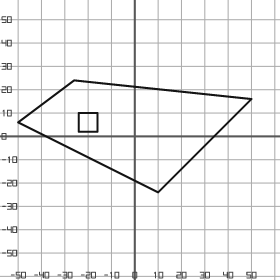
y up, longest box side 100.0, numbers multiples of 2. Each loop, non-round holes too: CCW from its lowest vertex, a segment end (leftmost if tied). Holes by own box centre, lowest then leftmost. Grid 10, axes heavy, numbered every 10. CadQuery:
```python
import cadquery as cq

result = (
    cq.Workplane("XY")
    .moveTo(10.0, -24.0)
    .lineTo(50.0, 16.0)
    .lineTo(-26.0, 24.0)
    .lineTo(-50.0, 6.0)
    .close()
    .moveTo(-24.0, 2.0)
    .lineTo(-16.0, 2.0)
    .lineTo(-16.0, 10.0)
    .lineTo(-24.0, 10.0)
    .close()
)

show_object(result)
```